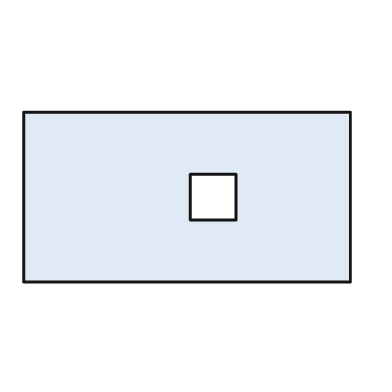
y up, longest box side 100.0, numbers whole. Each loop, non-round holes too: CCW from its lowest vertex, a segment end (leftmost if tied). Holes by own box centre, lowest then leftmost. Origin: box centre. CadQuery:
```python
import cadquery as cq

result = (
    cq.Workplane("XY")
    .moveTo(-50.0, -26.0)
    .lineTo(50.0, -26.0)
    .lineTo(50.0, 26.0)
    .lineTo(-50.0, 26.0)
    .close()
    .moveTo(1.0, -7.0)
    .lineTo(15.0, -7.0)
    .lineTo(15.0, 7.0)
    .lineTo(1.0, 7.0)
    .close()
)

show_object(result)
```